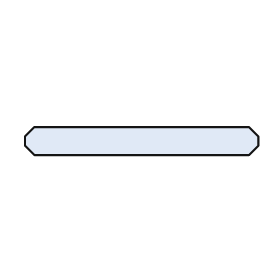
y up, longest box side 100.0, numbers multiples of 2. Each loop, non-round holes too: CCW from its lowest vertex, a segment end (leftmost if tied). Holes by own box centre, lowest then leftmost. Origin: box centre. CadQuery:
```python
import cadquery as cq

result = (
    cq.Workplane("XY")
    .moveTo(-46.0, -6.0)
    .lineTo(46.0, -6.0)
    .lineTo(50.0, -2.0)
    .lineTo(50.0, 2.0)
    .lineTo(46.0, 6.0)
    .lineTo(-46.0, 6.0)
    .lineTo(-50.0, 2.0)
    .lineTo(-50.0, -2.0)
    .close()
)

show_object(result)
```